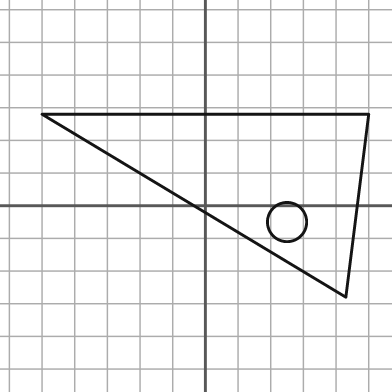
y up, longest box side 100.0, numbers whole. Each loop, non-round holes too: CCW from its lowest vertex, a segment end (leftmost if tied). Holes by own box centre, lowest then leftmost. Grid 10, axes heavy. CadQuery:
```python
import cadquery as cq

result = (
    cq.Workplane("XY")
    .moveTo(43.0, -28.0)
    .lineTo(50.0, 28.0)
    .lineTo(-50.0, 28.0)
    .close()
    .moveTo(25.0, -5.0)
    .circle(6.0)
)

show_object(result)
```